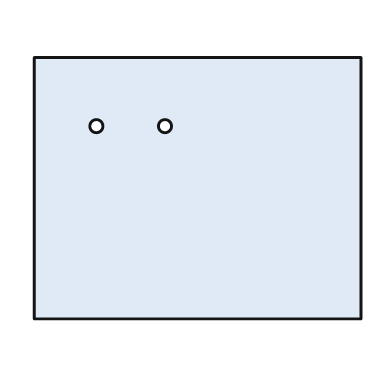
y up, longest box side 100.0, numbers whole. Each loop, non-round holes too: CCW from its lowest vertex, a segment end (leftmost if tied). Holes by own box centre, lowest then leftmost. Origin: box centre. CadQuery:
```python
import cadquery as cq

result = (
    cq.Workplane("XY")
    .moveTo(-50.0, -40.0)
    .lineTo(50.0, -40.0)
    .lineTo(50.0, 40.0)
    .lineTo(-50.0, 40.0)
    .close()
    .moveTo(-31.0, 19.0)
    .circle(2.0)
    .moveTo(-10.0, 19.0)
    .circle(2.0)
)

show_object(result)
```